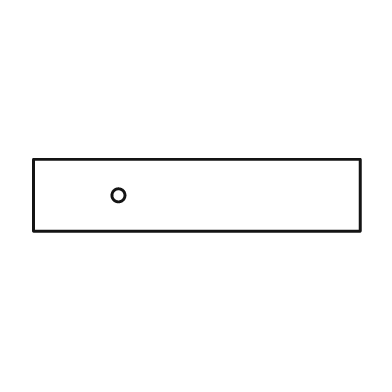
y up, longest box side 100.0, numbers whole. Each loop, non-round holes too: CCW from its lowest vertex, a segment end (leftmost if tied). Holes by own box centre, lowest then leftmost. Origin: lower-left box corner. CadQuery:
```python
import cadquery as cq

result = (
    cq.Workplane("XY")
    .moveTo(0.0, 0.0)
    .lineTo(100.0, 0.0)
    .lineTo(100.0, 22.0)
    .lineTo(0.0, 22.0)
    .close()
    .moveTo(26.0, 11.0)
    .circle(2.0)
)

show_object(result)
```